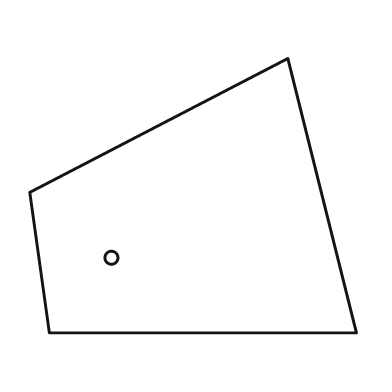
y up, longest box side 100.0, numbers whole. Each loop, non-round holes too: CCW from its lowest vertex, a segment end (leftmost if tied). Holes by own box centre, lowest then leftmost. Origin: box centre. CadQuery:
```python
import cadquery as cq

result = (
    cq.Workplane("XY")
    .moveTo(-44.0, -42.0)
    .lineTo(50.0, -42.0)
    .lineTo(29.0, 42.0)
    .lineTo(-50.0, 1.0)
    .close()
    .moveTo(-25.0, -19.0)
    .circle(2.0)
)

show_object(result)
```